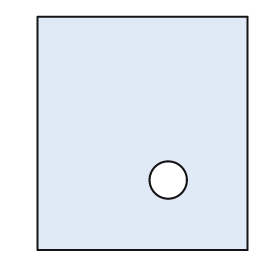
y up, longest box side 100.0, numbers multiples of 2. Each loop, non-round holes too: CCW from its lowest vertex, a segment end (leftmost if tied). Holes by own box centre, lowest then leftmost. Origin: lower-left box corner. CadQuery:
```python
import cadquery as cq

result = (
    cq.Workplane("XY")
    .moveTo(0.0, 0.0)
    .lineTo(90.0, 0.0)
    .lineTo(90.0, 100.0)
    .lineTo(0.0, 100.0)
    .close()
    .moveTo(56.0, 30.0)
    .circle(8.0)
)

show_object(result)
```